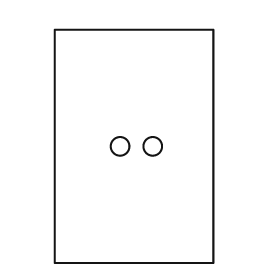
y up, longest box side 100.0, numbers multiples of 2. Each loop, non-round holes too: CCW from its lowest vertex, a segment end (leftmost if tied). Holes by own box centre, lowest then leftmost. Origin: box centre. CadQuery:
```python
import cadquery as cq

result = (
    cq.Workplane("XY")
    .moveTo(-34.0, -50.0)
    .lineTo(34.0, -50.0)
    .lineTo(34.0, 50.0)
    .lineTo(-34.0, 50.0)
    .close()
    .moveTo(-6.0, 0.0)
    .circle(4.0)
    .moveTo(8.0, 0.0)
    .circle(4.0)
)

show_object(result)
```